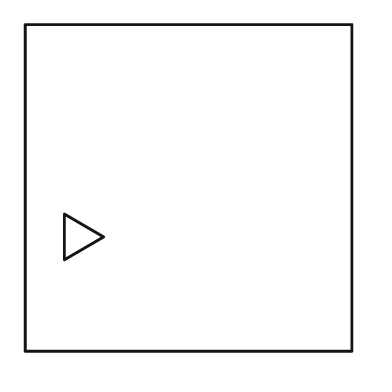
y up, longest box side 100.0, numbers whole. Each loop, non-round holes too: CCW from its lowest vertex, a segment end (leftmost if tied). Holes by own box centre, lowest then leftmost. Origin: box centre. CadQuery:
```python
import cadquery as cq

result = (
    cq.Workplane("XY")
    .moveTo(-50.0, -50.0)
    .lineTo(50.0, -50.0)
    .lineTo(50.0, 50.0)
    .lineTo(-50.0, 50.0)
    .close()
    .moveTo(-38.0, -22.0)
    .lineTo(-26.0, -15.0)
    .lineTo(-38.0, -8.0)
    .close()
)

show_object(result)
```